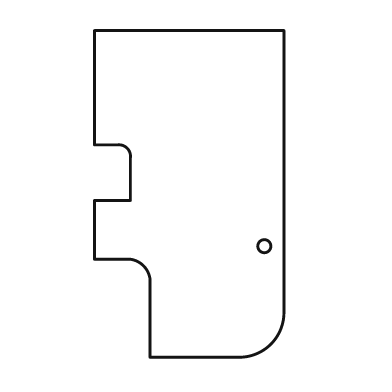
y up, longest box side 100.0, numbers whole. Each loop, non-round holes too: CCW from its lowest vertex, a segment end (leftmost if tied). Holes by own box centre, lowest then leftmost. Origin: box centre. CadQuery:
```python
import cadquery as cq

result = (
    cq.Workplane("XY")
    .moveTo(-12.0, -50.0)
    .lineTo(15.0, -50.0)
    .threePointArc((25.0, -46.0), (29.0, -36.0))
    .lineTo(29.0, 50.0)
    .lineTo(-29.0, 50.0)
    .lineTo(-29.0, 15.0)
    .lineTo(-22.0, 15.0)
    .threePointArc((-19.0, 14.0), (-18.0, 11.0))
    .lineTo(-18.0, -2.0)
    .lineTo(-29.0, -2.0)
    .lineTo(-29.0, -20.0)
    .lineTo(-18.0, -20.0)
    .threePointArc((-14.0, -22.0), (-12.0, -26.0))
    .close()
    .moveTo(23.0, -16.0)
    .circle(2.0)
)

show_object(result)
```